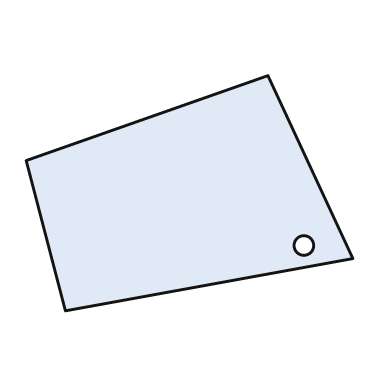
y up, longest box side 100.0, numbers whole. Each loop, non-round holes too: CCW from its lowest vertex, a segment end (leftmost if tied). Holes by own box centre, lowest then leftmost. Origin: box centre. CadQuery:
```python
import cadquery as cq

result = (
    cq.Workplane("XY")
    .moveTo(-38.0, -36.0)
    .lineTo(50.0, -20.0)
    .lineTo(24.0, 36.0)
    .lineTo(-50.0, 10.0)
    .close()
    .moveTo(35.0, -16.0)
    .circle(3.0)
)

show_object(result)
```